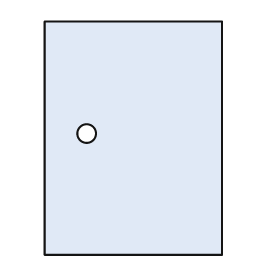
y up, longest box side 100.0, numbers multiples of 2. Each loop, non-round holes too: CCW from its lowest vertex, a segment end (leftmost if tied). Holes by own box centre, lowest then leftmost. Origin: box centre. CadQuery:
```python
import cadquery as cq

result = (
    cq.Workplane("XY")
    .moveTo(-38.0, -50.0)
    .lineTo(38.0, -50.0)
    .lineTo(38.0, 50.0)
    .lineTo(-38.0, 50.0)
    .close()
    .moveTo(-20.0, 2.0)
    .circle(4.0)
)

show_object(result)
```